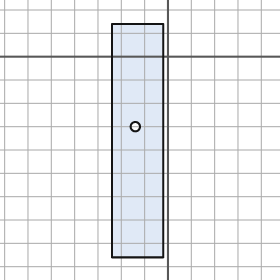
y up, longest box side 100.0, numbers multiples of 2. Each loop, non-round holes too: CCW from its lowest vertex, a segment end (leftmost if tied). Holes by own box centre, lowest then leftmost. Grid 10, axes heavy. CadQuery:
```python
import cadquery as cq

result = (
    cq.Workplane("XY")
    .moveTo(-24.0, -86.0)
    .lineTo(-2.0, -86.0)
    .lineTo(-2.0, 14.0)
    .lineTo(-24.0, 14.0)
    .close()
    .moveTo(-14.0, -30.0)
    .circle(2.0)
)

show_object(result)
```